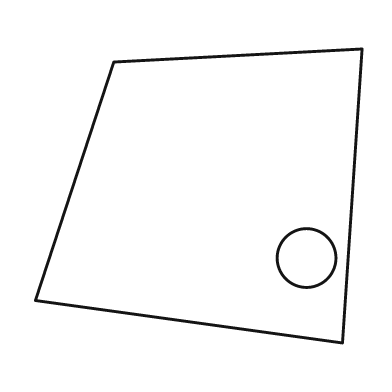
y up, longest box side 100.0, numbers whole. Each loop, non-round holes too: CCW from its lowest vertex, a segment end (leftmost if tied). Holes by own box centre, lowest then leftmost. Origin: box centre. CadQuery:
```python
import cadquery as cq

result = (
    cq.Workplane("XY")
    .moveTo(44.0, -45.0)
    .lineTo(50.0, 45.0)
    .lineTo(-26.0, 41.0)
    .lineTo(-50.0, -32.0)
    .close()
    .moveTo(33.0, -19.0)
    .circle(9.0)
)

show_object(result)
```